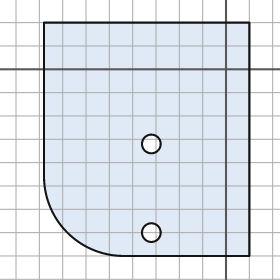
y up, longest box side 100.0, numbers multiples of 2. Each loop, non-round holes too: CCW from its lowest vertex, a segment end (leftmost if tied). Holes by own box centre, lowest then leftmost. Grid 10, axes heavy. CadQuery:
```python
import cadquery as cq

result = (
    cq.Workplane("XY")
    .moveTo(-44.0, -80.0)
    .lineTo(10.0, -80.0)
    .lineTo(10.0, 20.0)
    .lineTo(-78.0, 20.0)
    .lineTo(-78.0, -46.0)
    .threePointArc((-68.0, -70.0), (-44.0, -80.0))
    .close()
    .moveTo(-32.0, -70.0)
    .circle(4.0)
    .moveTo(-32.0, -32.0)
    .circle(4.0)
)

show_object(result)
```